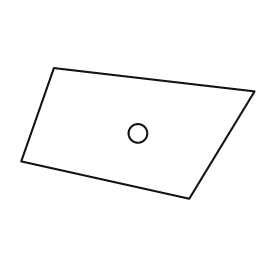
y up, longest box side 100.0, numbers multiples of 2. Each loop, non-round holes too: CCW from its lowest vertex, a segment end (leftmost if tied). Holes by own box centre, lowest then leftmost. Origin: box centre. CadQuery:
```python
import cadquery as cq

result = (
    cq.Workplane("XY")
    .moveTo(22.0, -28.0)
    .lineTo(50.0, 18.0)
    .lineTo(-36.0, 28.0)
    .lineTo(-50.0, -12.0)
    .close()
    .moveTo(0.0, 0.0)
    .circle(4.0)
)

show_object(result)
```